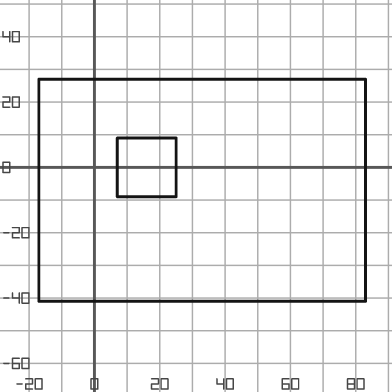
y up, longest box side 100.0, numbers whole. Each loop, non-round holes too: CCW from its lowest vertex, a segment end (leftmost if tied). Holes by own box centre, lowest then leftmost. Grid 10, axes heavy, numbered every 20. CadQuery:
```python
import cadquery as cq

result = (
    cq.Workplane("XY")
    .moveTo(-17.0, -41.0)
    .lineTo(83.0, -41.0)
    .lineTo(83.0, 27.0)
    .lineTo(-17.0, 27.0)
    .close()
    .moveTo(7.0, -9.0)
    .lineTo(25.0, -9.0)
    .lineTo(25.0, 9.0)
    .lineTo(7.0, 9.0)
    .close()
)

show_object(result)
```